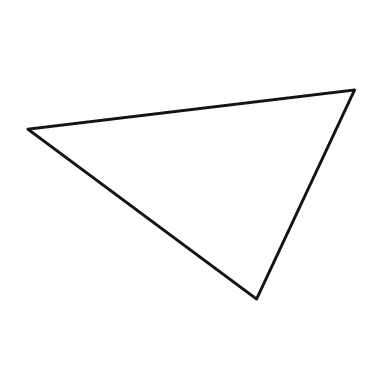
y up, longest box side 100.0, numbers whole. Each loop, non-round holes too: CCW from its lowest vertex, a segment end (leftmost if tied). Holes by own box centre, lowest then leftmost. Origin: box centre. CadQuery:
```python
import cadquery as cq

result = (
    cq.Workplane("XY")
    .moveTo(20.0, -32.0)
    .lineTo(50.0, 32.0)
    .lineTo(-50.0, 20.0)
    .close()
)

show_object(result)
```